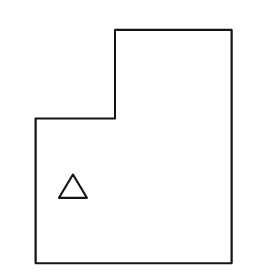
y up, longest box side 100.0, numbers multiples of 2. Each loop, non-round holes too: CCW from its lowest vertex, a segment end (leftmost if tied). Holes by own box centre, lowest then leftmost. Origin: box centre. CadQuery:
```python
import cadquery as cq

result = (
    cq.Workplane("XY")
    .moveTo(-42.0, -50.0)
    .lineTo(42.0, -50.0)
    .lineTo(42.0, 50.0)
    .lineTo(-8.0, 50.0)
    .lineTo(-8.0, 12.0)
    .lineTo(-42.0, 12.0)
    .close()
    .moveTo(-32.0, -22.0)
    .lineTo(-20.0, -22.0)
    .lineTo(-26.0, -12.0)
    .close()
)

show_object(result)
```